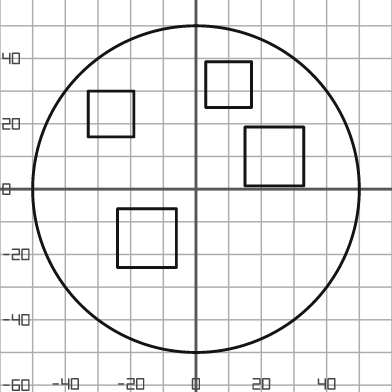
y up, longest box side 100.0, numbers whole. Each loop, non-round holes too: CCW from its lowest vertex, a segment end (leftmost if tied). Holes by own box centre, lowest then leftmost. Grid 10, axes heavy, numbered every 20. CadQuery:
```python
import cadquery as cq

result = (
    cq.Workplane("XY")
    .moveTo(0.0, 0.0)
    .circle(50.0)
    .moveTo(-24.0, -24.0)
    .lineTo(-6.0, -24.0)
    .lineTo(-6.0, -6.0)
    .lineTo(-24.0, -6.0)
    .close()
    .moveTo(15.0, 1.0)
    .lineTo(33.0, 1.0)
    .lineTo(33.0, 19.0)
    .lineTo(15.0, 19.0)
    .close()
    .moveTo(-33.0, 16.0)
    .lineTo(-19.0, 16.0)
    .lineTo(-19.0, 30.0)
    .lineTo(-33.0, 30.0)
    .close()
    .moveTo(3.0, 25.0)
    .lineTo(17.0, 25.0)
    .lineTo(17.0, 39.0)
    .lineTo(3.0, 39.0)
    .close()
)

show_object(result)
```